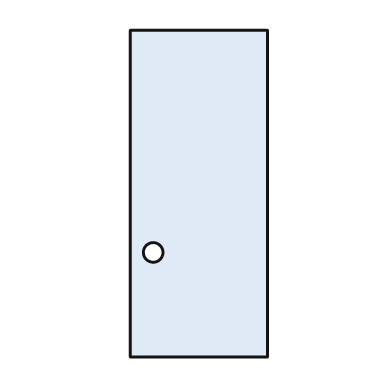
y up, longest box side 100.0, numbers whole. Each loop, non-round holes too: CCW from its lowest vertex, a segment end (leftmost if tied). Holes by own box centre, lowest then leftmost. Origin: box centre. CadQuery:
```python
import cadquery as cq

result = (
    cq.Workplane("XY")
    .moveTo(-21.0, -50.0)
    .lineTo(21.0, -50.0)
    .lineTo(21.0, 50.0)
    .lineTo(-21.0, 50.0)
    .close()
    .moveTo(-14.0, -18.0)
    .circle(3.0)
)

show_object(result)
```